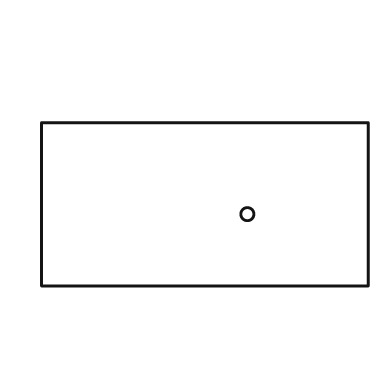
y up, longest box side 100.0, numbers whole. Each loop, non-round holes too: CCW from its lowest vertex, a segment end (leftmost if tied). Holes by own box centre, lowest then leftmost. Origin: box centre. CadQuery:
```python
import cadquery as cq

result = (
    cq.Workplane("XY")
    .moveTo(-50.0, -25.0)
    .lineTo(50.0, -25.0)
    .lineTo(50.0, 25.0)
    .lineTo(-50.0, 25.0)
    .close()
    .moveTo(13.0, -3.0)
    .circle(2.0)
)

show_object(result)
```